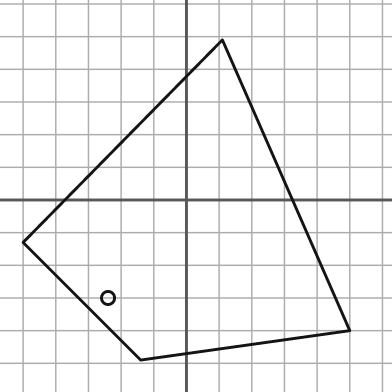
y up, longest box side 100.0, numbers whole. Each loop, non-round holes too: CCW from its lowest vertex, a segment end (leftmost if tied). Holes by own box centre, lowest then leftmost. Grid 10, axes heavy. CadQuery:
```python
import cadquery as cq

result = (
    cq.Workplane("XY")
    .moveTo(-14.0, -49.0)
    .lineTo(50.0, -40.0)
    .lineTo(11.0, 49.0)
    .lineTo(-50.0, -13.0)
    .close()
    .moveTo(-24.0, -30.0)
    .circle(2.0)
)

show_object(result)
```